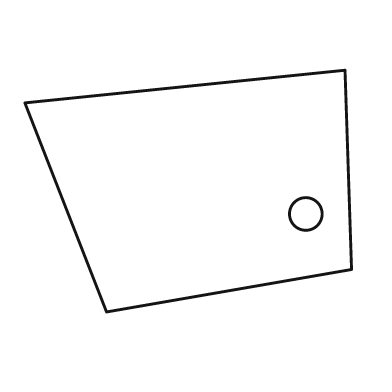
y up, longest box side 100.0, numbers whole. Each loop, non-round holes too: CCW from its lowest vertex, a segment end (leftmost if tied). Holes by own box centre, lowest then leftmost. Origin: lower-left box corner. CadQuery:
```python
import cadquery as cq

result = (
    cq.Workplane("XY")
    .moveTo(25.0, 0.0)
    .lineTo(100.0, 13.0)
    .lineTo(98.0, 74.0)
    .lineTo(0.0, 64.0)
    .close()
    .moveTo(86.0, 30.0)
    .circle(5.0)
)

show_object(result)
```